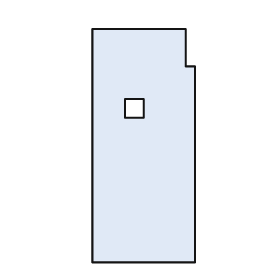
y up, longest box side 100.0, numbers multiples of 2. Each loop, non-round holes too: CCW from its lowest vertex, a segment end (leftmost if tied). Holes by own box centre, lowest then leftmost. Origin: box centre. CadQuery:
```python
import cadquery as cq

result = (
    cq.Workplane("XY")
    .moveTo(-22.0, -50.0)
    .lineTo(22.0, -50.0)
    .lineTo(22.0, 34.0)
    .lineTo(18.0, 34.0)
    .lineTo(18.0, 50.0)
    .lineTo(-22.0, 50.0)
    .close()
    .moveTo(-8.0, 12.0)
    .lineTo(0.0, 12.0)
    .lineTo(0.0, 20.0)
    .lineTo(-8.0, 20.0)
    .close()
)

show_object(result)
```